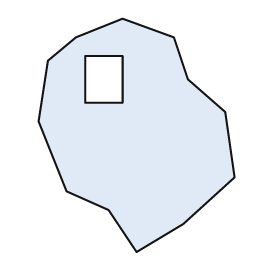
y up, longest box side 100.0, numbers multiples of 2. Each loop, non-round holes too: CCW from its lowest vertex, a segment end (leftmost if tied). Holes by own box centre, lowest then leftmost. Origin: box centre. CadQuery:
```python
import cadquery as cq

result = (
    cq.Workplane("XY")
    .moveTo(0.0, -50.0)
    .lineTo(20.0, -38.0)
    .lineTo(42.0, -18.0)
    .lineTo(38.0, 10.0)
    .lineTo(22.0, 24.0)
    .lineTo(16.0, 42.0)
    .lineTo(-6.0, 50.0)
    .lineTo(-26.0, 42.0)
    .lineTo(-38.0, 32.0)
    .lineTo(-42.0, 6.0)
    .lineTo(-30.0, -24.0)
    .lineTo(-12.0, -32.0)
    .close()
    .moveTo(-22.0, 14.0)
    .lineTo(-6.0, 14.0)
    .lineTo(-6.0, 34.0)
    .lineTo(-22.0, 34.0)
    .close()
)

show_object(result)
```